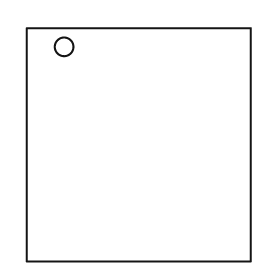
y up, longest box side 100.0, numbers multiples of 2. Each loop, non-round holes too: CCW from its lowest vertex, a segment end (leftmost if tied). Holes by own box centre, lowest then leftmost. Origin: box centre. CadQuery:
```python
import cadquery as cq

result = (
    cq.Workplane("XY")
    .moveTo(-48.0, -50.0)
    .lineTo(48.0, -50.0)
    .lineTo(48.0, 50.0)
    .lineTo(-48.0, 50.0)
    .close()
    .moveTo(-32.0, 42.0)
    .circle(4.0)
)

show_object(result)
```